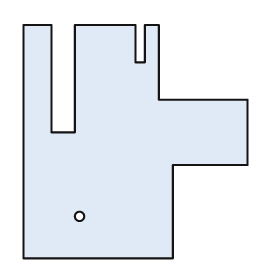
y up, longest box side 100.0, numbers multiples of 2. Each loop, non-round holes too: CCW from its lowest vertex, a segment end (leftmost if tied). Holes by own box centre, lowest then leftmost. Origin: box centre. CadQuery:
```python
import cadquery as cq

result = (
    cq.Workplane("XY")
    .moveTo(-48.0, -50.0)
    .lineTo(16.0, -50.0)
    .lineTo(16.0, -10.0)
    .lineTo(48.0, -10.0)
    .lineTo(48.0, 18.0)
    .lineTo(10.0, 18.0)
    .lineTo(10.0, 50.0)
    .lineTo(4.0, 50.0)
    .lineTo(4.0, 34.0)
    .lineTo(0.0, 34.0)
    .lineTo(0.0, 50.0)
    .lineTo(-26.0, 50.0)
    .lineTo(-26.0, 4.0)
    .lineTo(-36.0, 4.0)
    .lineTo(-36.0, 50.0)
    .lineTo(-48.0, 50.0)
    .close()
    .moveTo(-24.0, -32.0)
    .circle(2.0)
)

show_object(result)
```